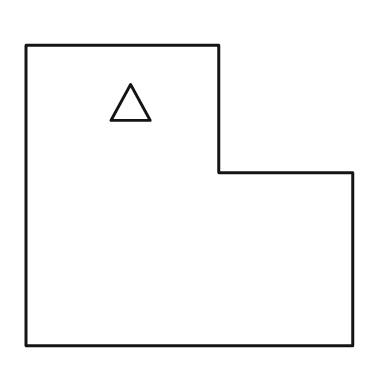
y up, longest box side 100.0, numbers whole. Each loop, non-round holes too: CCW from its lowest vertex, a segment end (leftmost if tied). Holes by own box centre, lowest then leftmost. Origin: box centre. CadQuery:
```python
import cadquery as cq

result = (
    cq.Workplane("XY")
    .moveTo(-50.0, -46.0)
    .lineTo(50.0, -46.0)
    .lineTo(50.0, 7.0)
    .lineTo(9.0, 7.0)
    .lineTo(9.0, 46.0)
    .lineTo(-50.0, 46.0)
    .close()
    .moveTo(-24.0, 23.0)
    .lineTo(-12.0, 23.0)
    .lineTo(-18.0, 34.0)
    .close()
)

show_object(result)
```